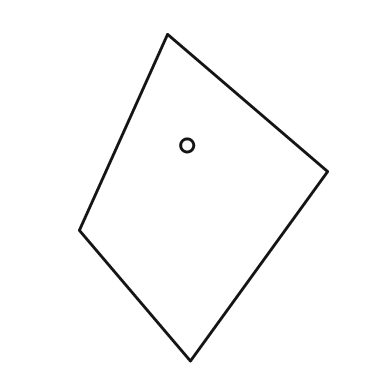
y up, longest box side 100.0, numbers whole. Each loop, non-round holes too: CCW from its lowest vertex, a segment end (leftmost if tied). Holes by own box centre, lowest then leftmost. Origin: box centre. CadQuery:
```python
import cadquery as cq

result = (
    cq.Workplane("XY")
    .moveTo(-4.0, -50.0)
    .lineTo(38.0, 8.0)
    .lineTo(-11.0, 50.0)
    .lineTo(-38.0, -10.0)
    .close()
    .moveTo(-5.0, 16.0)
    .circle(2.0)
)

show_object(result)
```